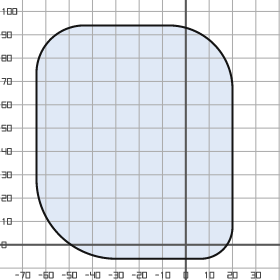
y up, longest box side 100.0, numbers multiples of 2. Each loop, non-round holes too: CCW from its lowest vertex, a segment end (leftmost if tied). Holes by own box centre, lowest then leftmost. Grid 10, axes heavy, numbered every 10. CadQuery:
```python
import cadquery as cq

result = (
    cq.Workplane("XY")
    .moveTo(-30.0, -6.0)
    .lineTo(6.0, -6.0)
    .threePointArc((16.0, -2.0), (20.0, 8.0))
    .lineTo(20.0, 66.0)
    .threePointArc((12.0, 86.0), (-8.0, 94.0))
    .lineTo(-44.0, 94.0)
    .threePointArc((-58.0, 88.0), (-64.0, 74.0))
    .lineTo(-64.0, 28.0)
    .threePointArc((-54.0, 4.0), (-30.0, -6.0))
    .close()
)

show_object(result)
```